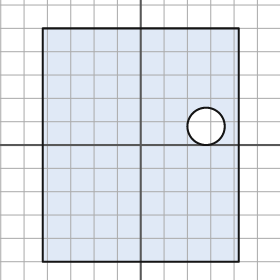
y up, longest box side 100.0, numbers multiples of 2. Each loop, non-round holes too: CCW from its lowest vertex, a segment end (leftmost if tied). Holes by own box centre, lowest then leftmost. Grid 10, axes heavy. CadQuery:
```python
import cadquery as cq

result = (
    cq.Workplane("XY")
    .moveTo(-42.0, -50.0)
    .lineTo(42.0, -50.0)
    .lineTo(42.0, 50.0)
    .lineTo(-42.0, 50.0)
    .close()
    .moveTo(28.0, 8.0)
    .circle(8.0)
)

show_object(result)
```